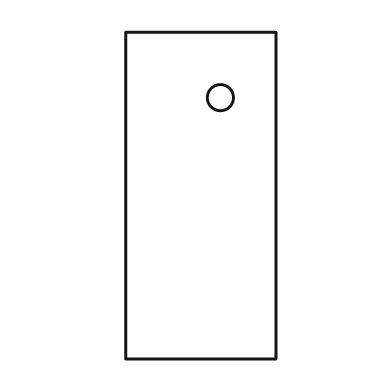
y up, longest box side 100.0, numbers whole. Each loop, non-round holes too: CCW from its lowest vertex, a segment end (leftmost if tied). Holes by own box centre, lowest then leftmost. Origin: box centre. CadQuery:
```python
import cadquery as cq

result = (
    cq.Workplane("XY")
    .moveTo(-23.0, -50.0)
    .lineTo(23.0, -50.0)
    .lineTo(23.0, 50.0)
    .lineTo(-23.0, 50.0)
    .close()
    .moveTo(6.0, 30.0)
    .circle(4.0)
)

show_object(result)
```